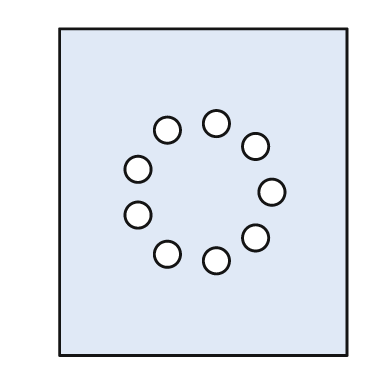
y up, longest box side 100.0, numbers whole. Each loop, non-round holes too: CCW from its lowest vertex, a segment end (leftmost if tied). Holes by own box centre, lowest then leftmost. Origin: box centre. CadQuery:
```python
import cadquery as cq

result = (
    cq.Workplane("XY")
    .moveTo(-44.0, -50.0)
    .lineTo(44.0, -50.0)
    .lineTo(44.0, 50.0)
    .lineTo(-44.0, 50.0)
    .close()
    .moveTo(4.0, -21.0)
    .circle(4.0)
    .moveTo(-11.0, -19.0)
    .circle(4.0)
    .moveTo(16.0, -14.0)
    .circle(4.0)
    .moveTo(-20.0, -7.0)
    .circle(4.0)
    .moveTo(21.0, 0.0)
    .circle(4.0)
    .moveTo(-20.0, 7.0)
    .circle(4.0)
    .moveTo(16.0, 14.0)
    .circle(4.0)
    .moveTo(-11.0, 19.0)
    .circle(4.0)
    .moveTo(4.0, 21.0)
    .circle(4.0)
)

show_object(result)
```